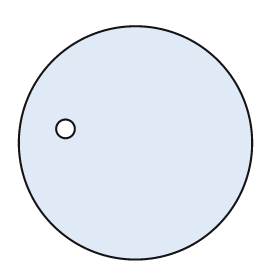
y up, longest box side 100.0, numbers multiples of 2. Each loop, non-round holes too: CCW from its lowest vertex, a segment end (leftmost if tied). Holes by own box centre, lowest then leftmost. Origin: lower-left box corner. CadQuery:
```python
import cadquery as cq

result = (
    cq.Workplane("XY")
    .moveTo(50.0, 50.0)
    .circle(50.0)
    .moveTo(20.0, 56.0)
    .circle(4.0)
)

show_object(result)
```